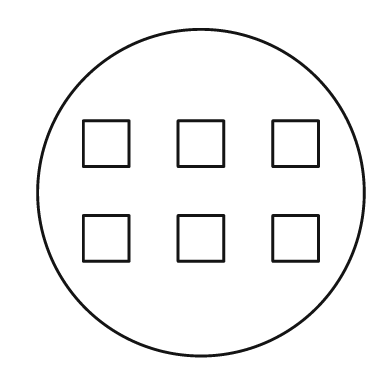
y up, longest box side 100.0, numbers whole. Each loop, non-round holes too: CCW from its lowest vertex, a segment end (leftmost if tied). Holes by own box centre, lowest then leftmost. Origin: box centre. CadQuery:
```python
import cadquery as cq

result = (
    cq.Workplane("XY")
    .moveTo(0.0, 0.0)
    .circle(50.0)
    .moveTo(-36.0, -21.0)
    .lineTo(-22.0, -21.0)
    .lineTo(-22.0, -7.0)
    .lineTo(-36.0, -7.0)
    .close()
    .moveTo(-7.0, -21.0)
    .lineTo(7.0, -21.0)
    .lineTo(7.0, -7.0)
    .lineTo(-7.0, -7.0)
    .close()
    .moveTo(22.0, -21.0)
    .lineTo(36.0, -21.0)
    .lineTo(36.0, -7.0)
    .lineTo(22.0, -7.0)
    .close()
    .moveTo(-36.0, 8.0)
    .lineTo(-22.0, 8.0)
    .lineTo(-22.0, 22.0)
    .lineTo(-36.0, 22.0)
    .close()
    .moveTo(-7.0, 8.0)
    .lineTo(7.0, 8.0)
    .lineTo(7.0, 22.0)
    .lineTo(-7.0, 22.0)
    .close()
    .moveTo(22.0, 8.0)
    .lineTo(36.0, 8.0)
    .lineTo(36.0, 22.0)
    .lineTo(22.0, 22.0)
    .close()
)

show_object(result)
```